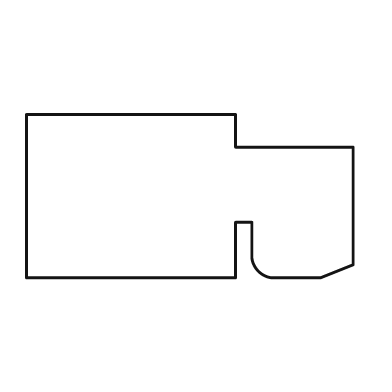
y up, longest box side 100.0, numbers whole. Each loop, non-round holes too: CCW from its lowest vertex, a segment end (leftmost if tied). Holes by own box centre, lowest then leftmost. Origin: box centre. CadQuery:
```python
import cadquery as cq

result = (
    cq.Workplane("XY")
    .moveTo(-50.0, -25.0)
    .lineTo(14.0, -25.0)
    .lineTo(14.0, -8.0)
    .lineTo(19.0, -8.0)
    .lineTo(19.0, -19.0)
    .threePointArc((21.0, -23.0), (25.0, -25.0))
    .lineTo(40.0, -25.0)
    .lineTo(50.0, -21.0)
    .lineTo(50.0, 15.0)
    .lineTo(14.0, 15.0)
    .lineTo(14.0, 25.0)
    .lineTo(-50.0, 25.0)
    .close()
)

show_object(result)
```